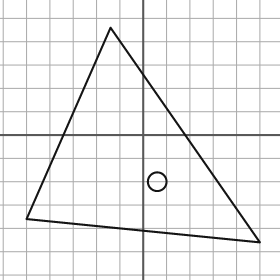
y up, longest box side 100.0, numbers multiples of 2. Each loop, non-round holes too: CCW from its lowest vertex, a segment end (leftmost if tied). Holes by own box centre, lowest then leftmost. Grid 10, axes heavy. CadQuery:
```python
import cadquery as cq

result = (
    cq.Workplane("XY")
    .moveTo(50.0, -46.0)
    .lineTo(-14.0, 46.0)
    .lineTo(-50.0, -36.0)
    .close()
    .moveTo(6.0, -20.0)
    .circle(4.0)
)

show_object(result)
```